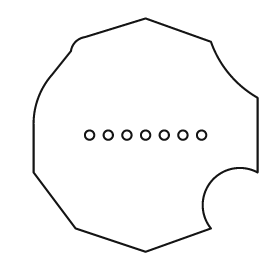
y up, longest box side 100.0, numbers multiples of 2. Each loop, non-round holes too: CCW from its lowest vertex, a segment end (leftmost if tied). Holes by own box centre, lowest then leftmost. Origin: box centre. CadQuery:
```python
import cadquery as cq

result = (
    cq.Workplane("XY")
    .moveTo(0.0, -50.0)
    .lineTo(28.0, -40.0)
    .threePointArc((28.0, -20.0), (48.0, -16.0))
    .lineTo(48.0, 16.0)
    .threePointArc((36.0, 26.0), (28.0, 40.0))
    .lineTo(0.0, 50.0)
    .lineTo(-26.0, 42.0)
    .threePointArc((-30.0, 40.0), (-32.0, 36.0))
    .lineTo(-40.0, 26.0)
    .threePointArc((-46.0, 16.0), (-48.0, 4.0))
    .lineTo(-48.0, -16.0)
    .lineTo(-30.0, -40.0)
    .close()
    .moveTo(-24.0, 0.0)
    .circle(2.0)
    .moveTo(-16.0, 0.0)
    .circle(2.0)
    .moveTo(-8.0, 0.0)
    .circle(2.0)
    .moveTo(0.0, 0.0)
    .circle(2.0)
    .moveTo(8.0, 0.0)
    .circle(2.0)
    .moveTo(16.0, 0.0)
    .circle(2.0)
    .moveTo(24.0, 0.0)
    .circle(2.0)
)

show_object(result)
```